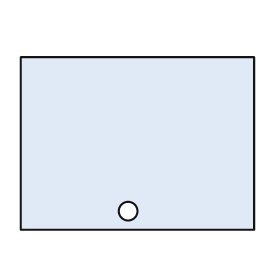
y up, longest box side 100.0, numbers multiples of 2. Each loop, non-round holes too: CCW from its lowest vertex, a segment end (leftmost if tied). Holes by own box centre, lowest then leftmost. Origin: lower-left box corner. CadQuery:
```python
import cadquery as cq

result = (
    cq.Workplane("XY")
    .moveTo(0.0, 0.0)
    .lineTo(100.0, 0.0)
    .lineTo(100.0, 74.0)
    .lineTo(0.0, 74.0)
    .close()
    .moveTo(46.0, 8.0)
    .circle(4.0)
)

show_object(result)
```